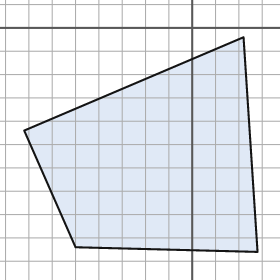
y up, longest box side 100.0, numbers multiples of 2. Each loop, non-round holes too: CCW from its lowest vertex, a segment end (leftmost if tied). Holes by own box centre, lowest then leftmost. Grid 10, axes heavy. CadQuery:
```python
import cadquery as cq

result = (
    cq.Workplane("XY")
    .moveTo(28.0, -96.0)
    .lineTo(22.0, -4.0)
    .lineTo(-72.0, -44.0)
    .lineTo(-50.0, -94.0)
    .close()
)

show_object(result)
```